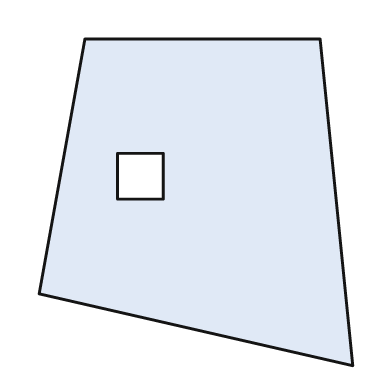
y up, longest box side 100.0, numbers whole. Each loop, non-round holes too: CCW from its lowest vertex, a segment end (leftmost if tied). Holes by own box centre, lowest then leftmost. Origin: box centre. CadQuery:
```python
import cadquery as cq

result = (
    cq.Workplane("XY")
    .moveTo(48.0, -50.0)
    .lineTo(38.0, 50.0)
    .lineTo(-34.0, 50.0)
    .lineTo(-48.0, -28.0)
    .close()
    .moveTo(-24.0, 1.0)
    .lineTo(-10.0, 1.0)
    .lineTo(-10.0, 15.0)
    .lineTo(-24.0, 15.0)
    .close()
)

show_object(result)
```